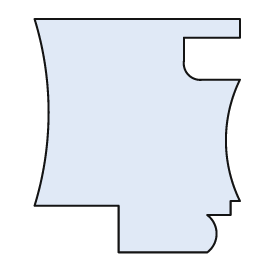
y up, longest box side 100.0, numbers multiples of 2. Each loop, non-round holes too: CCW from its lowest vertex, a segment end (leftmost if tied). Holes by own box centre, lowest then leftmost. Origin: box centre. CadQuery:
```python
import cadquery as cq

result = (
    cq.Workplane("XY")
    .moveTo(-8.0, -50.0)
    .lineTo(30.0, -50.0)
    .threePointArc((34.0, -42.0), (30.0, -34.0))
    .lineTo(40.0, -34.0)
    .lineTo(40.0, -28.0)
    .lineTo(44.0, -28.0)
    .threePointArc((38.0, -2.0), (44.0, 24.0))
    .lineTo(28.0, 24.0)
    .threePointArc((22.0, 26.0), (20.0, 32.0))
    .lineTo(20.0, 42.0)
    .lineTo(44.0, 42.0)
    .lineTo(44.0, 50.0)
    .lineTo(-44.0, 50.0)
    .threePointArc((-38.0, 10.0), (-44.0, -30.0))
    .lineTo(-8.0, -30.0)
    .close()
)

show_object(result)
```